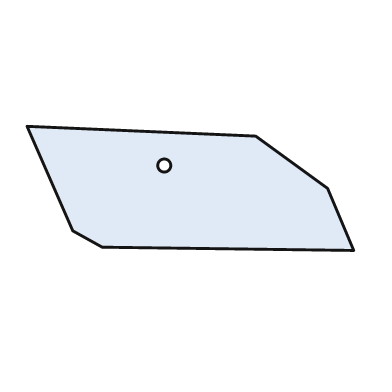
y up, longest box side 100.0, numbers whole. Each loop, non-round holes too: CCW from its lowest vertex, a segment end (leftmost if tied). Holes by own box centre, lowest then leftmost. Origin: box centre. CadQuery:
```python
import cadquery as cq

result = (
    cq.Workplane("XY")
    .moveTo(50.0, -19.0)
    .lineTo(42.0, 0.0)
    .lineTo(20.0, 16.0)
    .lineTo(-50.0, 19.0)
    .lineTo(-36.0, -13.0)
    .lineTo(-27.0, -18.0)
    .close()
    .moveTo(-8.0, 7.0)
    .circle(2.0)
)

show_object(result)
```